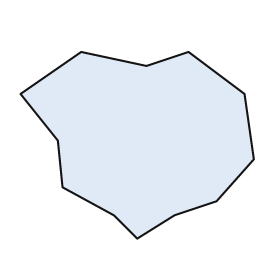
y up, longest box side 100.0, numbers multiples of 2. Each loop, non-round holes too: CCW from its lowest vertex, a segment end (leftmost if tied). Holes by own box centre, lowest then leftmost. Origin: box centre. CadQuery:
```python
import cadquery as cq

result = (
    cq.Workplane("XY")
    .moveTo(0.0, -40.0)
    .lineTo(16.0, -30.0)
    .lineTo(34.0, -24.0)
    .lineTo(50.0, -6.0)
    .lineTo(46.0, 22.0)
    .lineTo(22.0, 40.0)
    .lineTo(4.0, 34.0)
    .lineTo(-24.0, 40.0)
    .lineTo(-50.0, 22.0)
    .lineTo(-34.0, 2.0)
    .lineTo(-32.0, -18.0)
    .lineTo(-10.0, -30.0)
    .close()
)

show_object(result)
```